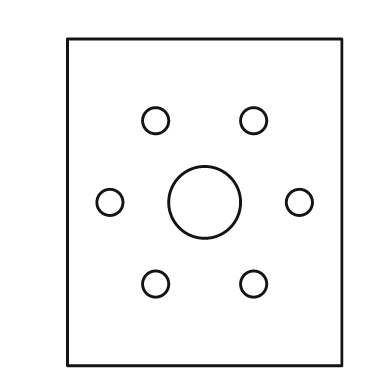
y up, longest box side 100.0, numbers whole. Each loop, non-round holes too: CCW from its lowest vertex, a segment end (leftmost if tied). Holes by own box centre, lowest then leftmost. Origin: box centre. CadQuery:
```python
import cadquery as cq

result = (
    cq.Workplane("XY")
    .moveTo(-42.0, -50.0)
    .lineTo(42.0, -50.0)
    .lineTo(42.0, 50.0)
    .lineTo(-42.0, 50.0)
    .close()
    .moveTo(-15.0, -25.0)
    .circle(4.0)
    .moveTo(15.0, -25.0)
    .circle(4.0)
    .moveTo(-29.0, 0.0)
    .circle(4.0)
    .moveTo(0.0, 0.0)
    .circle(11.0)
    .moveTo(29.0, 0.0)
    .circle(4.0)
    .moveTo(-15.0, 25.0)
    .circle(4.0)
    .moveTo(15.0, 25.0)
    .circle(4.0)
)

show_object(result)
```